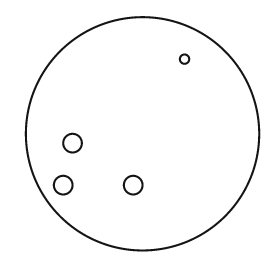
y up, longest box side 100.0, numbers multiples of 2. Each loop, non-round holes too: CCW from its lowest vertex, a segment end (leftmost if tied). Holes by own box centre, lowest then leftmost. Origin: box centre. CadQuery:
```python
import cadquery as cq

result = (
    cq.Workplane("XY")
    .moveTo(0.0, 0.0)
    .circle(50.0)
    .moveTo(-34.0, -22.0)
    .circle(4.0)
    .moveTo(-4.0, -22.0)
    .circle(4.0)
    .moveTo(-30.0, -4.0)
    .circle(4.0)
    .moveTo(18.0, 32.0)
    .circle(2.0)
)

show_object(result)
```